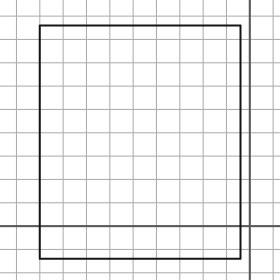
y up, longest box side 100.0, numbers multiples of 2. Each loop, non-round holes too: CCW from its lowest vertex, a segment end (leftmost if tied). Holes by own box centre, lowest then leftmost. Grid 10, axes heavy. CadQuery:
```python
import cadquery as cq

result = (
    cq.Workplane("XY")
    .moveTo(-90.0, -14.0)
    .lineTo(-4.0, -14.0)
    .lineTo(-4.0, 86.0)
    .lineTo(-90.0, 86.0)
    .close()
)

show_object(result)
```